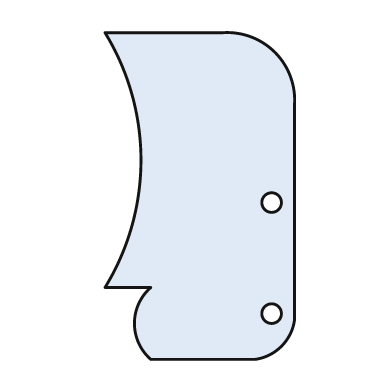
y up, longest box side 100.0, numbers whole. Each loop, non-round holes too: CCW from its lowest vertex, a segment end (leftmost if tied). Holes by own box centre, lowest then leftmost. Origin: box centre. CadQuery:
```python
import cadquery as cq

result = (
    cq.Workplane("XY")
    .moveTo(-15.0, -50.0)
    .lineTo(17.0, -50.0)
    .threePointArc((25.0, -46.0), (29.0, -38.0))
    .lineTo(29.0, 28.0)
    .threePointArc((23.0, 44.0), (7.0, 50.0))
    .lineTo(-29.0, 50.0)
    .threePointArc((-18.0, 11.0), (-29.0, -28.0))
    .lineTo(-15.0, -28.0)
    .threePointArc((-20.0, -39.0), (-15.0, -50.0))
    .close()
    .moveTo(22.0, -36.0)
    .circle(3.0)
    .moveTo(22.0, -2.0)
    .circle(3.0)
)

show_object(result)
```